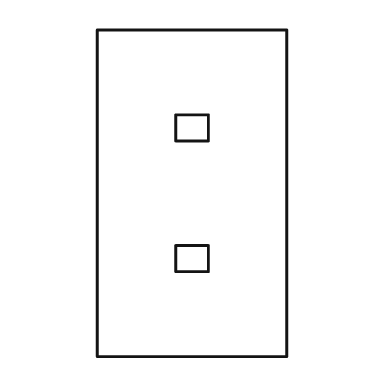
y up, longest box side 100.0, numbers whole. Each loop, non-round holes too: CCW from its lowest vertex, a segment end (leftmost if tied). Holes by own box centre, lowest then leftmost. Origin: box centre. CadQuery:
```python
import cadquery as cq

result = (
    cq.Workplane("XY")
    .moveTo(-29.0, -50.0)
    .lineTo(29.0, -50.0)
    .lineTo(29.0, 50.0)
    .lineTo(-29.0, 50.0)
    .close()
    .moveTo(-5.0, -24.0)
    .lineTo(5.0, -24.0)
    .lineTo(5.0, -16.0)
    .lineTo(-5.0, -16.0)
    .close()
    .moveTo(-5.0, 16.0)
    .lineTo(5.0, 16.0)
    .lineTo(5.0, 24.0)
    .lineTo(-5.0, 24.0)
    .close()
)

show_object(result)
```